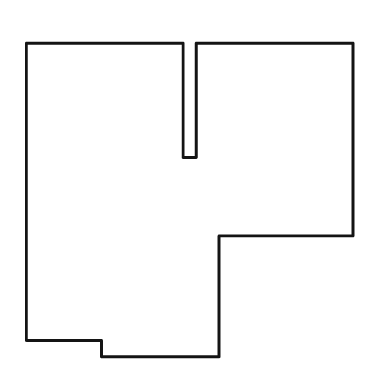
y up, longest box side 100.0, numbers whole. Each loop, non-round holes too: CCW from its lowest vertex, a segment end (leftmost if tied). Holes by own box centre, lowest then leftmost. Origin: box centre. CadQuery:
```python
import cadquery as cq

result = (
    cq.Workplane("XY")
    .moveTo(-27.0, -48.0)
    .lineTo(9.0, -48.0)
    .lineTo(9.0, -11.0)
    .lineTo(50.0, -11.0)
    .lineTo(50.0, 48.0)
    .lineTo(2.0, 48.0)
    .lineTo(2.0, 13.0)
    .lineTo(-2.0, 13.0)
    .lineTo(-2.0, 48.0)
    .lineTo(-50.0, 48.0)
    .lineTo(-50.0, -43.0)
    .lineTo(-27.0, -43.0)
    .close()
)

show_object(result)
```